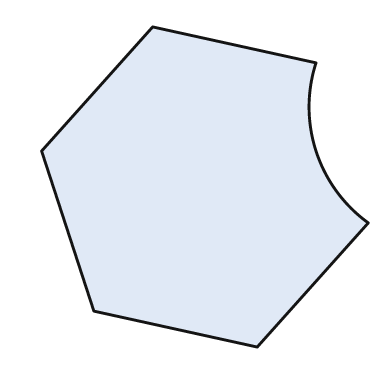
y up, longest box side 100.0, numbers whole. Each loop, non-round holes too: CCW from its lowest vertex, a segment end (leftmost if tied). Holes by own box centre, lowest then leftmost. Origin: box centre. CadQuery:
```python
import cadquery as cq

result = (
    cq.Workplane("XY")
    .moveTo(16.0, -49.0)
    .lineTo(50.0, -11.0)
    .threePointArc((34.0, 11.0), (34.0, 38.0))
    .lineTo(-16.0, 49.0)
    .lineTo(-50.0, 11.0)
    .lineTo(-34.0, -38.0)
    .close()
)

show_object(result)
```